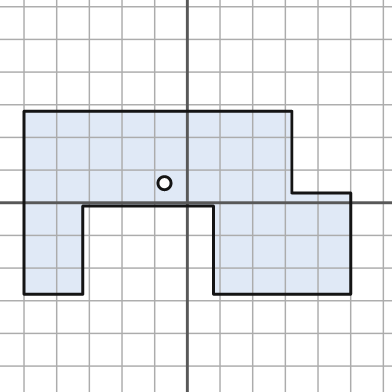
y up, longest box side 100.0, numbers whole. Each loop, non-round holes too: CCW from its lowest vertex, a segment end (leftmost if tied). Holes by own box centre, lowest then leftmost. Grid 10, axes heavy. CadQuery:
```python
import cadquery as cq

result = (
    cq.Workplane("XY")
    .moveTo(-50.0, -28.0)
    .lineTo(-32.0, -28.0)
    .lineTo(-32.0, -1.0)
    .lineTo(8.0, -1.0)
    .lineTo(8.0, -28.0)
    .lineTo(50.0, -28.0)
    .lineTo(50.0, 3.0)
    .lineTo(32.0, 3.0)
    .lineTo(32.0, 28.0)
    .lineTo(-50.0, 28.0)
    .close()
    .moveTo(-7.0, 6.0)
    .circle(2.0)
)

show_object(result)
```